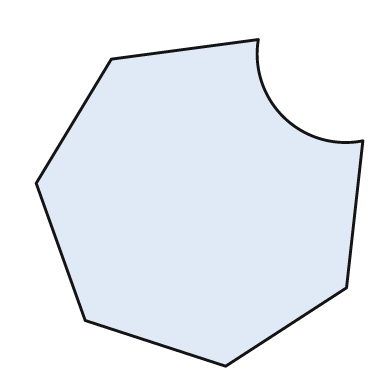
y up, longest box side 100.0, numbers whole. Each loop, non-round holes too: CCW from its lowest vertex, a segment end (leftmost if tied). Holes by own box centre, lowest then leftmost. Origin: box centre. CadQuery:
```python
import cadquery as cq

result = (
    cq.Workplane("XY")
    .moveTo(8.0, -50.0)
    .lineTo(45.0, -26.0)
    .lineTo(50.0, 19.0)
    .threePointArc((26.0, 26.0), (18.0, 50.0))
    .lineTo(-27.0, 44.0)
    .lineTo(-50.0, 6.0)
    .lineTo(-35.0, -36.0)
    .close()
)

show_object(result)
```